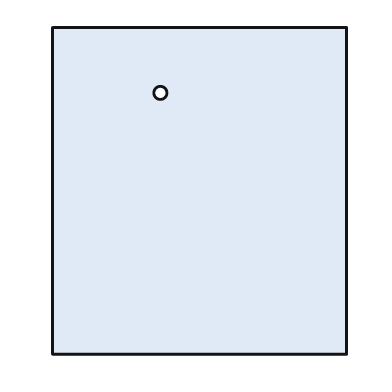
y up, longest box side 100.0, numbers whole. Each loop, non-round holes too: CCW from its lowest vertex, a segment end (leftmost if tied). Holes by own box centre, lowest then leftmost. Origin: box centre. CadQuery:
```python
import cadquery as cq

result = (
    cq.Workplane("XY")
    .moveTo(-45.0, -50.0)
    .lineTo(45.0, -50.0)
    .lineTo(45.0, 50.0)
    .lineTo(-45.0, 50.0)
    .close()
    .moveTo(-12.0, 30.0)
    .circle(2.0)
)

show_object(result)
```